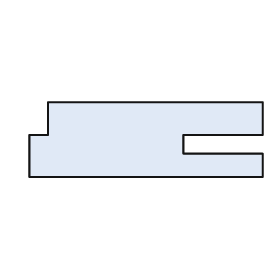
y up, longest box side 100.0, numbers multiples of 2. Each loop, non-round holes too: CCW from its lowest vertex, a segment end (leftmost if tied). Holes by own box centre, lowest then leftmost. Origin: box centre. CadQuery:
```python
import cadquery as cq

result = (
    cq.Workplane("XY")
    .moveTo(-50.0, -16.0)
    .lineTo(50.0, -16.0)
    .lineTo(50.0, -6.0)
    .lineTo(16.0, -6.0)
    .lineTo(16.0, 2.0)
    .lineTo(50.0, 2.0)
    .lineTo(50.0, 16.0)
    .lineTo(-42.0, 16.0)
    .lineTo(-42.0, 2.0)
    .lineTo(-50.0, 2.0)
    .close()
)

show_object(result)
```